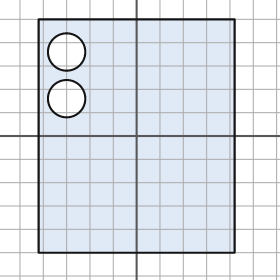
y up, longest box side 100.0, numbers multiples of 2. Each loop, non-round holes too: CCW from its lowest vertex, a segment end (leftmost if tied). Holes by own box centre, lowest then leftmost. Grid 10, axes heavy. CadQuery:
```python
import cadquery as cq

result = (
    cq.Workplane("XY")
    .moveTo(-42.0, -50.0)
    .lineTo(42.0, -50.0)
    .lineTo(42.0, 50.0)
    .lineTo(-42.0, 50.0)
    .close()
    .moveTo(-30.0, 16.0)
    .circle(8.0)
    .moveTo(-30.0, 36.0)
    .circle(8.0)
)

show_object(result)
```